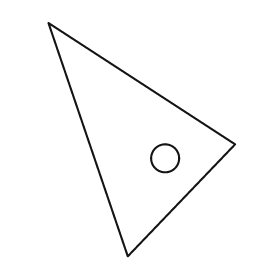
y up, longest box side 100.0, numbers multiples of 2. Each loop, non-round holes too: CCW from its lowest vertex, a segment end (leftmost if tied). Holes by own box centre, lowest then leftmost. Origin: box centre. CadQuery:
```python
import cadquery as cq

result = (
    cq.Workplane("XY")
    .moveTo(-6.0, -50.0)
    .lineTo(40.0, -2.0)
    .lineTo(-40.0, 50.0)
    .close()
    .moveTo(10.0, -8.0)
    .circle(6.0)
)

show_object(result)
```